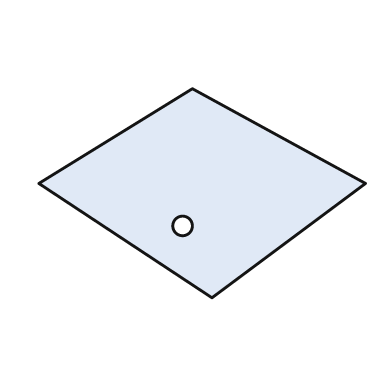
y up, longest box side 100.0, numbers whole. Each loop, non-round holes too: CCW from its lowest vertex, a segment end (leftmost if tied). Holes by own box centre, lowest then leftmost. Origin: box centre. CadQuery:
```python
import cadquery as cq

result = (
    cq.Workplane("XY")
    .moveTo(3.0, -32.0)
    .lineTo(50.0, 3.0)
    .lineTo(-3.0, 32.0)
    .lineTo(-50.0, 3.0)
    .close()
    .moveTo(-6.0, -10.0)
    .circle(3.0)
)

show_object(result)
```